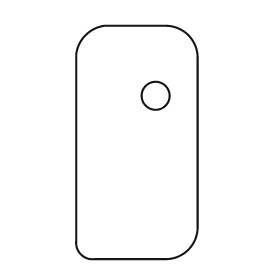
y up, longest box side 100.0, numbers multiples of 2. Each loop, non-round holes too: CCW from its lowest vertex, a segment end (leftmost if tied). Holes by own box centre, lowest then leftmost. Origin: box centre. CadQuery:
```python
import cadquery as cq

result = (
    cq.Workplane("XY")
    .moveTo(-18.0, -50.0)
    .lineTo(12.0, -50.0)
    .threePointArc((22.0, -46.0), (26.0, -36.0))
    .lineTo(26.0, 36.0)
    .threePointArc((22.0, 46.0), (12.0, 50.0))
    .lineTo(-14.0, 50.0)
    .threePointArc((-22.0, 46.0), (-26.0, 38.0))
    .lineTo(-26.0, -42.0)
    .threePointArc((-24.0, -48.0), (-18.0, -50.0))
    .close()
    .moveTo(8.0, 20.0)
    .circle(6.0)
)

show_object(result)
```